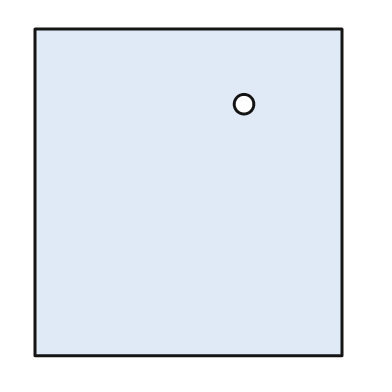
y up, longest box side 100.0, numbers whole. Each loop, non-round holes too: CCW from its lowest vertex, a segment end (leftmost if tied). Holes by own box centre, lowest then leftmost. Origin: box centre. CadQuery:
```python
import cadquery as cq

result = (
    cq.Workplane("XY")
    .moveTo(-47.0, -50.0)
    .lineTo(47.0, -50.0)
    .lineTo(47.0, 50.0)
    .lineTo(-47.0, 50.0)
    .close()
    .moveTo(17.0, 27.0)
    .circle(3.0)
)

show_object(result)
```